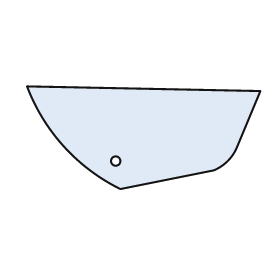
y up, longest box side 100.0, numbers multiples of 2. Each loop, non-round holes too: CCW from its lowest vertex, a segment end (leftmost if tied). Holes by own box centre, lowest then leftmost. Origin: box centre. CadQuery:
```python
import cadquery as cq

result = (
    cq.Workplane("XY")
    .moveTo(-10.0, -22.0)
    .lineTo(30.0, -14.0)
    .threePointArc((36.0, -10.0), (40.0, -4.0))
    .lineTo(50.0, 20.0)
    .lineTo(-50.0, 22.0)
    .threePointArc((-34.0, -4.0), (-10.0, -22.0))
    .close()
    .moveTo(-12.0, -10.0)
    .circle(2.0)
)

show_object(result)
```